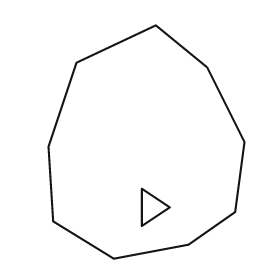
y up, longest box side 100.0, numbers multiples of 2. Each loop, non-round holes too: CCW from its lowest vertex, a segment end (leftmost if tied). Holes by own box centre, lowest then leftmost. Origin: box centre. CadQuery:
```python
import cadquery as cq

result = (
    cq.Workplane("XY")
    .moveTo(-14.0, -50.0)
    .lineTo(18.0, -44.0)
    .lineTo(38.0, -30.0)
    .lineTo(42.0, 0.0)
    .lineTo(26.0, 32.0)
    .lineTo(4.0, 50.0)
    .lineTo(-30.0, 34.0)
    .lineTo(-42.0, -2.0)
    .lineTo(-40.0, -34.0)
    .close()
    .moveTo(-2.0, -36.0)
    .lineTo(10.0, -28.0)
    .lineTo(-2.0, -20.0)
    .close()
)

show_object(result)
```